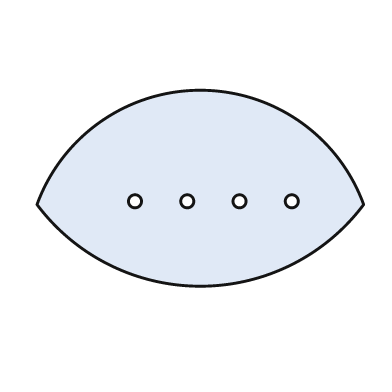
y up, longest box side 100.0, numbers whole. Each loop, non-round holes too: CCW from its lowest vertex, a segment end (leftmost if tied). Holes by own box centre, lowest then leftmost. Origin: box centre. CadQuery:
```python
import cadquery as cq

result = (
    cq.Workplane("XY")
    .moveTo(-50.0, -5.0)
    .threePointArc((0.0, -30.0), (50.0, -5.0))
    .threePointArc((0.0, 30.0), (-50.0, -5.0))
    .close()
    .moveTo(-20.0, -4.0)
    .circle(2.0)
    .moveTo(-4.0, -4.0)
    .circle(2.0)
    .moveTo(12.0, -4.0)
    .circle(2.0)
    .moveTo(28.0, -4.0)
    .circle(2.0)
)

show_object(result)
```